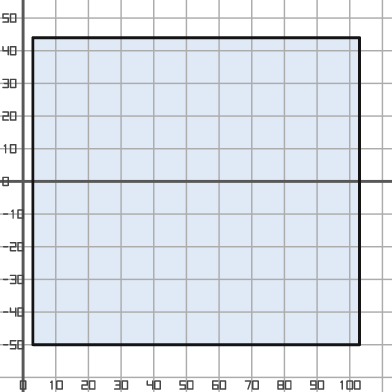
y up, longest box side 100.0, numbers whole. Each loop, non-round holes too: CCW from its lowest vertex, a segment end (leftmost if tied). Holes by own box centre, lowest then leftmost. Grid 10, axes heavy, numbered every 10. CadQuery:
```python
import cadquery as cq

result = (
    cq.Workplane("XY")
    .moveTo(3.0, -50.0)
    .lineTo(103.0, -50.0)
    .lineTo(103.0, 44.0)
    .lineTo(3.0, 44.0)
    .close()
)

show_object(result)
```